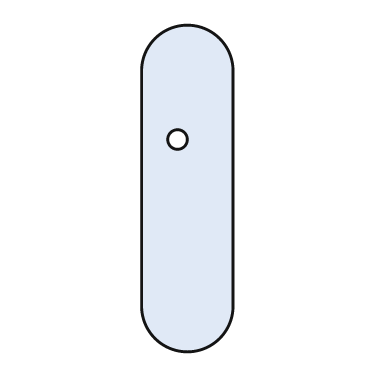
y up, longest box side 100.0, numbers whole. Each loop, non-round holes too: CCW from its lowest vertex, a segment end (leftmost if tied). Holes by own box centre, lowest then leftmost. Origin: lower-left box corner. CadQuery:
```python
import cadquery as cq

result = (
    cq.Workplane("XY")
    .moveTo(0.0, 14.0)
    .threePointArc((14.0, 0.0), (28.0, 14.0))
    .lineTo(28.0, 86.0)
    .threePointArc((14.0, 100.0), (0.0, 86.0))
    .close()
    .moveTo(11.0, 65.0)
    .circle(3.0)
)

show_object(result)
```